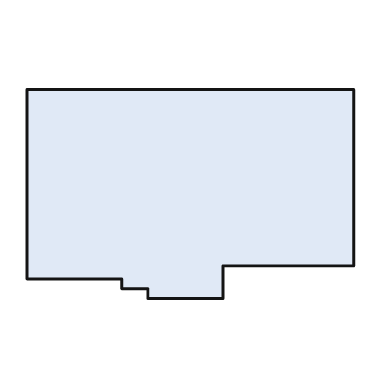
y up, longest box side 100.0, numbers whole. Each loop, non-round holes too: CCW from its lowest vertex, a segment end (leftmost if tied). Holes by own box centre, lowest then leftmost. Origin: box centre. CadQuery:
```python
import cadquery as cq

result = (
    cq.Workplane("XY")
    .moveTo(-13.0, -32.0)
    .lineTo(10.0, -32.0)
    .lineTo(10.0, -22.0)
    .lineTo(50.0, -22.0)
    .lineTo(50.0, 32.0)
    .lineTo(-50.0, 32.0)
    .lineTo(-50.0, -26.0)
    .lineTo(-21.0, -26.0)
    .lineTo(-21.0, -29.0)
    .lineTo(-13.0, -29.0)
    .close()
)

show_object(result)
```